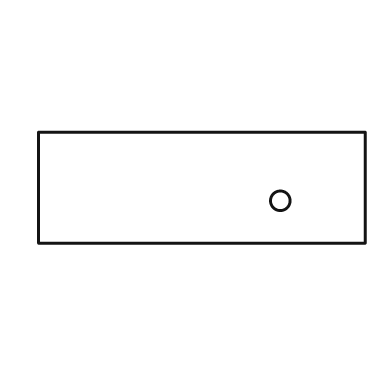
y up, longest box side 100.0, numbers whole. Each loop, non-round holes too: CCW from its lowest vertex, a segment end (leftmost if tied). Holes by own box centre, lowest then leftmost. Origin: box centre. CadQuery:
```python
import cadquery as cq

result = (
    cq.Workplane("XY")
    .moveTo(-50.0, -17.0)
    .lineTo(50.0, -17.0)
    .lineTo(50.0, 17.0)
    .lineTo(-50.0, 17.0)
    .close()
    .moveTo(24.0, -4.0)
    .circle(3.0)
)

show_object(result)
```